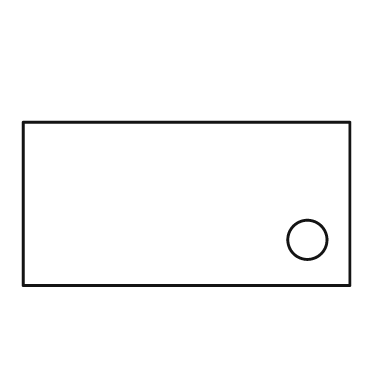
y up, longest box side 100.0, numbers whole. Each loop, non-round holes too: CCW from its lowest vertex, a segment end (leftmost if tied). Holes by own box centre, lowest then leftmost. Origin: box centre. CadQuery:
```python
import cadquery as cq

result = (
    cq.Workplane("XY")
    .moveTo(-50.0, -25.0)
    .lineTo(50.0, -25.0)
    .lineTo(50.0, 25.0)
    .lineTo(-50.0, 25.0)
    .close()
    .moveTo(37.0, -11.0)
    .circle(6.0)
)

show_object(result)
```